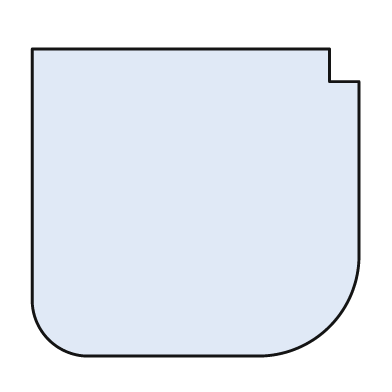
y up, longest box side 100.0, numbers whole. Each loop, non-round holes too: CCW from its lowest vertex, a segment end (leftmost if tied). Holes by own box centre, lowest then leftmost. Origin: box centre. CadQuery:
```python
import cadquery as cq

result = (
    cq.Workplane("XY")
    .moveTo(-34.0, -47.0)
    .lineTo(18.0, -47.0)
    .threePointArc((41.0, -38.0), (50.0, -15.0))
    .lineTo(50.0, 37.0)
    .lineTo(41.0, 37.0)
    .lineTo(41.0, 47.0)
    .lineTo(-50.0, 47.0)
    .lineTo(-50.0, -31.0)
    .threePointArc((-45.0, -42.0), (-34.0, -47.0))
    .close()
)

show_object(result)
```